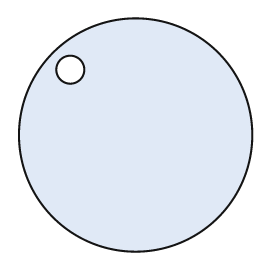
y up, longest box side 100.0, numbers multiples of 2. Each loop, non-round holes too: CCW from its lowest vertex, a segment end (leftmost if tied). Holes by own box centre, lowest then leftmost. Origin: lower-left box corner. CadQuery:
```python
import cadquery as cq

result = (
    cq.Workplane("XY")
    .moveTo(50.0, 50.0)
    .circle(50.0)
    .moveTo(22.0, 78.0)
    .circle(6.0)
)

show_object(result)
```